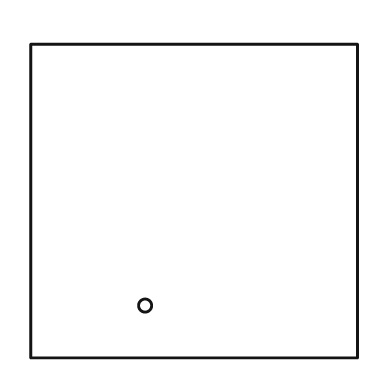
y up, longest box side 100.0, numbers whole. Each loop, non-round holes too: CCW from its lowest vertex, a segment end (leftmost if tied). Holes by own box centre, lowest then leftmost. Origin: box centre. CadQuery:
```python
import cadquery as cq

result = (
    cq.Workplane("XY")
    .moveTo(-50.0, -48.0)
    .lineTo(50.0, -48.0)
    .lineTo(50.0, 48.0)
    .lineTo(-50.0, 48.0)
    .close()
    .moveTo(-15.0, -32.0)
    .circle(2.0)
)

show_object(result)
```